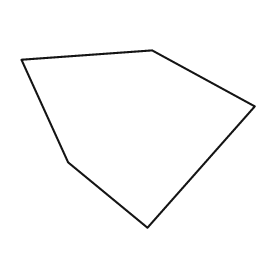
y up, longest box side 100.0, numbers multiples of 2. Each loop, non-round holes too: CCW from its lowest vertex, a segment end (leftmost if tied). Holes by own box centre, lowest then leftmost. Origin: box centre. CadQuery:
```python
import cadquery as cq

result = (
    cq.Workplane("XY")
    .moveTo(4.0, -38.0)
    .lineTo(50.0, 14.0)
    .lineTo(6.0, 38.0)
    .lineTo(-50.0, 34.0)
    .lineTo(-30.0, -10.0)
    .close()
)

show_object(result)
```